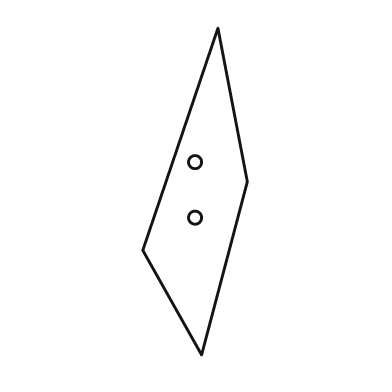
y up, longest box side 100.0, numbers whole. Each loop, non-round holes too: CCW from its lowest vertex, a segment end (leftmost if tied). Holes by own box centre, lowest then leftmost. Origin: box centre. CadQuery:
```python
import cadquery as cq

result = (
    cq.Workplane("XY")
    .moveTo(2.0, -50.0)
    .lineTo(16.0, 3.0)
    .lineTo(7.0, 50.0)
    .lineTo(-16.0, -18.0)
    .close()
    .moveTo(0.0, -8.0)
    .circle(2.0)
    .moveTo(0.0, 9.0)
    .circle(2.0)
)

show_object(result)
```